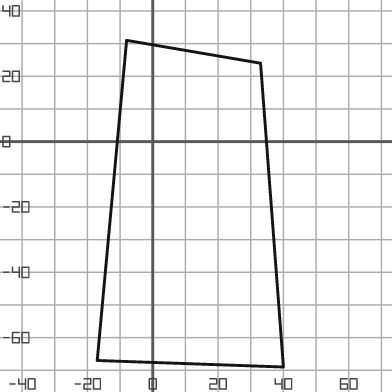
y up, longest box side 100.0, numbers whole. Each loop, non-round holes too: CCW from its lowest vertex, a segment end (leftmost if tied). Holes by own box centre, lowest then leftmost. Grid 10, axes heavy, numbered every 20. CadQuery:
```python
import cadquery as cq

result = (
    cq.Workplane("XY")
    .moveTo(40.0, -69.0)
    .lineTo(33.0, 24.0)
    .lineTo(-8.0, 31.0)
    .lineTo(-17.0, -67.0)
    .close()
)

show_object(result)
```